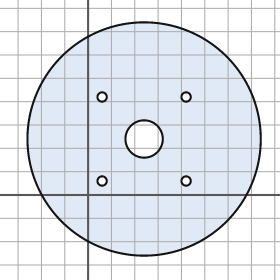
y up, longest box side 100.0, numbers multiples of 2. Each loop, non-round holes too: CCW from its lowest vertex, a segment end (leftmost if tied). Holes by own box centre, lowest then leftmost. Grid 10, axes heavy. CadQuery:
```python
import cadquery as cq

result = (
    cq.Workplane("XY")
    .moveTo(24.0, 24.0)
    .circle(50.0)
    .moveTo(6.0, 6.0)
    .circle(2.0)
    .moveTo(42.0, 6.0)
    .circle(2.0)
    .moveTo(24.0, 24.0)
    .circle(8.0)
    .moveTo(6.0, 42.0)
    .circle(2.0)
    .moveTo(42.0, 42.0)
    .circle(2.0)
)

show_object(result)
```